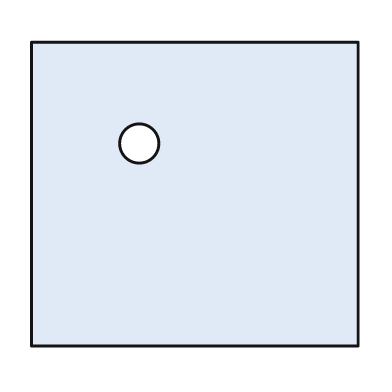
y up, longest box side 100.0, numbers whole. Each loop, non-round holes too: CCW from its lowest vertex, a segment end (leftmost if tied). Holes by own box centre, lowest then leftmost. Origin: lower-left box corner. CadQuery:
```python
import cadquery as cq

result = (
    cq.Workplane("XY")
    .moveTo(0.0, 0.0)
    .lineTo(100.0, 0.0)
    .lineTo(100.0, 93.0)
    .lineTo(0.0, 93.0)
    .close()
    .moveTo(33.0, 62.0)
    .circle(6.0)
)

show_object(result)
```